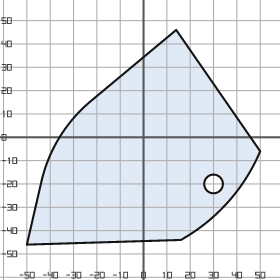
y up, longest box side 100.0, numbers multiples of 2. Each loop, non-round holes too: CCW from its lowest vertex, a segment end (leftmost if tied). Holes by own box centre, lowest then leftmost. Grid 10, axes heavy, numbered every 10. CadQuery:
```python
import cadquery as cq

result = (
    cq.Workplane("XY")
    .moveTo(-50.0, -46.0)
    .lineTo(16.0, -44.0)
    .threePointArc((36.0, -28.0), (50.0, -6.0))
    .lineTo(14.0, 46.0)
    .lineTo(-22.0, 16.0)
    .threePointArc((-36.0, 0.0), (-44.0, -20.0))
    .close()
    .moveTo(30.0, -20.0)
    .circle(4.0)
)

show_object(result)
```